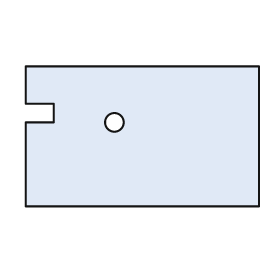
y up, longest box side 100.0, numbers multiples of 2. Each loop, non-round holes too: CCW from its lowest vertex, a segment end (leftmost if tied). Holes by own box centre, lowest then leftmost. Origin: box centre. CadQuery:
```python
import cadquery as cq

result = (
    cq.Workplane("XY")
    .moveTo(-50.0, -30.0)
    .lineTo(50.0, -30.0)
    .lineTo(50.0, 30.0)
    .lineTo(-50.0, 30.0)
    .lineTo(-50.0, 14.0)
    .lineTo(-38.0, 14.0)
    .lineTo(-38.0, 6.0)
    .lineTo(-50.0, 6.0)
    .close()
    .moveTo(-12.0, 6.0)
    .circle(4.0)
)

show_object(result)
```